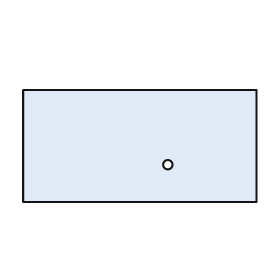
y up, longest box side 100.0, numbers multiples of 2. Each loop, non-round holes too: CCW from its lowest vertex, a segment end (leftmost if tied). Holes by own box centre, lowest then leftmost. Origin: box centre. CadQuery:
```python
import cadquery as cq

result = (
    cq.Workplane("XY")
    .moveTo(-50.0, -24.0)
    .lineTo(50.0, -24.0)
    .lineTo(50.0, 24.0)
    .lineTo(-50.0, 24.0)
    .close()
    .moveTo(12.0, -8.0)
    .circle(2.0)
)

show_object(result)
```